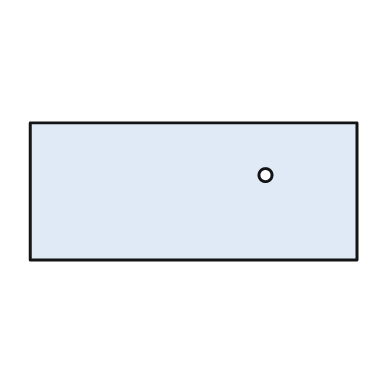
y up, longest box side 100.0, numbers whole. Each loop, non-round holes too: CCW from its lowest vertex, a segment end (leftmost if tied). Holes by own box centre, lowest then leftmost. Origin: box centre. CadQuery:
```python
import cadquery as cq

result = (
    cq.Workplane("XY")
    .moveTo(-50.0, -21.0)
    .lineTo(50.0, -21.0)
    .lineTo(50.0, 21.0)
    .lineTo(-50.0, 21.0)
    .close()
    .moveTo(22.0, 5.0)
    .circle(2.0)
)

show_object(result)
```